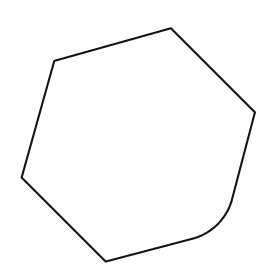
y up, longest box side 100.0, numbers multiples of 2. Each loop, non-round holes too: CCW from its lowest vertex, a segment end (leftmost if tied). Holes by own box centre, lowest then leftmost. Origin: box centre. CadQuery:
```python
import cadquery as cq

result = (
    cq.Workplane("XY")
    .moveTo(-14.0, -50.0)
    .lineTo(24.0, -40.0)
    .threePointArc((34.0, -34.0), (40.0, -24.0))
    .lineTo(50.0, 14.0)
    .lineTo(14.0, 50.0)
    .lineTo(-36.0, 36.0)
    .lineTo(-50.0, -14.0)
    .close()
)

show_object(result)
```